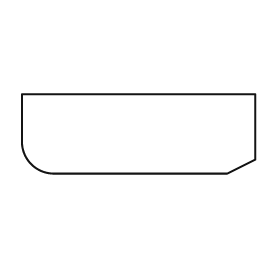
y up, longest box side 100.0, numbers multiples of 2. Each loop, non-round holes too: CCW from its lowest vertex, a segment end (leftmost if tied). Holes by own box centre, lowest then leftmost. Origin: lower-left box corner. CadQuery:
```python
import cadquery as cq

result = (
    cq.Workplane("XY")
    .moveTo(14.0, 0.0)
    .lineTo(88.0, 0.0)
    .lineTo(100.0, 6.0)
    .lineTo(100.0, 34.0)
    .lineTo(0.0, 34.0)
    .lineTo(0.0, 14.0)
    .threePointArc((4.0, 4.0), (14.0, 0.0))
    .close()
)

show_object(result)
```